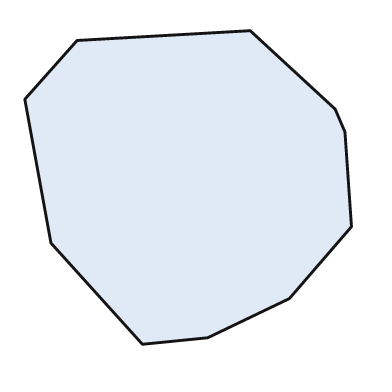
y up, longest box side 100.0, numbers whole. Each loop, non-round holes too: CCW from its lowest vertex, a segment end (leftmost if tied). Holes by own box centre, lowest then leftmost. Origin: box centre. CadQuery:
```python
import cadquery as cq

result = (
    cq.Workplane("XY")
    .moveTo(-14.0, -48.0)
    .lineTo(6.0, -46.0)
    .lineTo(31.0, -34.0)
    .lineTo(50.0, -12.0)
    .lineTo(48.0, 17.0)
    .lineTo(45.0, 24.0)
    .lineTo(19.0, 48.0)
    .lineTo(-34.0, 45.0)
    .lineTo(-50.0, 27.0)
    .lineTo(-42.0, -17.0)
    .close()
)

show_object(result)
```